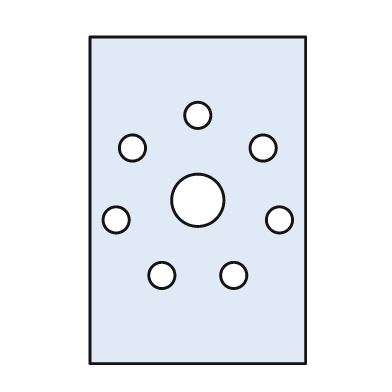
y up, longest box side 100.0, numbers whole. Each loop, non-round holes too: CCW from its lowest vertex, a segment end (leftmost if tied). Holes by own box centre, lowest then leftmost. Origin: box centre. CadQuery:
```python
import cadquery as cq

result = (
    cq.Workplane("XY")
    .moveTo(-33.0, -50.0)
    .lineTo(33.0, -50.0)
    .lineTo(33.0, 50.0)
    .lineTo(-33.0, 50.0)
    .close()
    .moveTo(-11.0, -23.0)
    .circle(4.0)
    .moveTo(11.0, -23.0)
    .circle(4.0)
    .moveTo(-25.0, -6.0)
    .circle(4.0)
    .moveTo(25.0, -6.0)
    .circle(4.0)
    .moveTo(0.0, 0.0)
    .circle(8.0)
    .moveTo(-20.0, 16.0)
    .circle(4.0)
    .moveTo(20.0, 16.0)
    .circle(4.0)
    .moveTo(0.0, 26.0)
    .circle(4.0)
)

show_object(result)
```